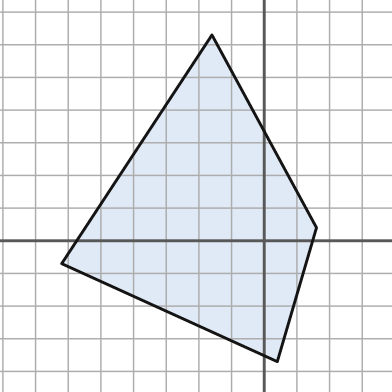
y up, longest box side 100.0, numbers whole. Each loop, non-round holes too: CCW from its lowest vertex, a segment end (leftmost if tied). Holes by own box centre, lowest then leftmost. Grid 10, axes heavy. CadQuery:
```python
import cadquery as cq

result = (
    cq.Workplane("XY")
    .moveTo(4.0, -37.0)
    .lineTo(16.0, 4.0)
    .lineTo(-16.0, 63.0)
    .lineTo(-62.0, -7.0)
    .close()
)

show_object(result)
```